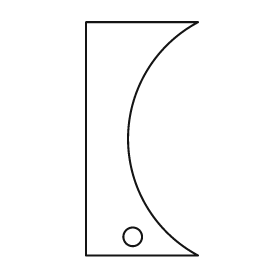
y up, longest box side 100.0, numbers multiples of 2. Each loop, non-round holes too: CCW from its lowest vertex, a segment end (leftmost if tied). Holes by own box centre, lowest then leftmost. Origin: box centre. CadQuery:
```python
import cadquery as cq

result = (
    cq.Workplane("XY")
    .moveTo(-24.0, -50.0)
    .lineTo(24.0, -50.0)
    .threePointArc((-6.0, 0.0), (24.0, 50.0))
    .lineTo(-24.0, 50.0)
    .close()
    .moveTo(-4.0, -42.0)
    .circle(4.0)
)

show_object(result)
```